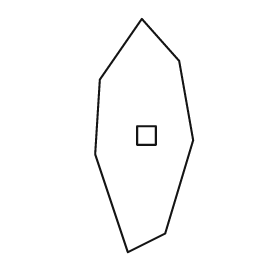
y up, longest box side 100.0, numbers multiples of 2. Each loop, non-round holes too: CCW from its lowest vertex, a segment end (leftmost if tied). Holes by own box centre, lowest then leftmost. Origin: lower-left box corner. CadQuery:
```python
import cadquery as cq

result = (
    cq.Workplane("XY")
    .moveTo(14.0, 0.0)
    .lineTo(30.0, 8.0)
    .lineTo(42.0, 48.0)
    .lineTo(36.0, 82.0)
    .lineTo(20.0, 100.0)
    .lineTo(2.0, 74.0)
    .lineTo(0.0, 42.0)
    .close()
    .moveTo(18.0, 46.0)
    .lineTo(26.0, 46.0)
    .lineTo(26.0, 54.0)
    .lineTo(18.0, 54.0)
    .close()
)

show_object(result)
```